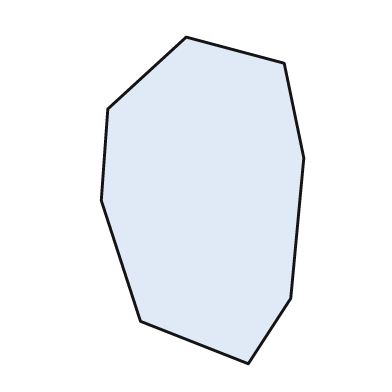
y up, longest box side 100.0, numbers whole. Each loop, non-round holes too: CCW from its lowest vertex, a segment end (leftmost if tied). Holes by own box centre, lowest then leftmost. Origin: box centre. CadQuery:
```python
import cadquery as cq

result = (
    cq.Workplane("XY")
    .moveTo(14.0, -50.0)
    .lineTo(27.0, -30.0)
    .lineTo(31.0, 13.0)
    .lineTo(25.0, 42.0)
    .lineTo(-5.0, 50.0)
    .lineTo(-29.0, 28.0)
    .lineTo(-31.0, 0.0)
    .lineTo(-19.0, -37.0)
    .close()
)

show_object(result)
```